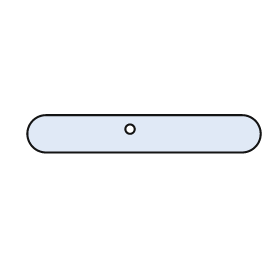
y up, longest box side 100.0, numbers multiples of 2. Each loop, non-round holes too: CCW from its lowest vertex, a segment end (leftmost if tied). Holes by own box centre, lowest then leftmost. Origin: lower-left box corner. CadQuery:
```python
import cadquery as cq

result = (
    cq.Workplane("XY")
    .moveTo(8.0, 0.0)
    .lineTo(92.0, 0.0)
    .threePointArc((100.0, 8.0), (92.0, 16.0))
    .lineTo(8.0, 16.0)
    .threePointArc((0.0, 8.0), (8.0, 0.0))
    .close()
    .moveTo(44.0, 10.0)
    .circle(2.0)
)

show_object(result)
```